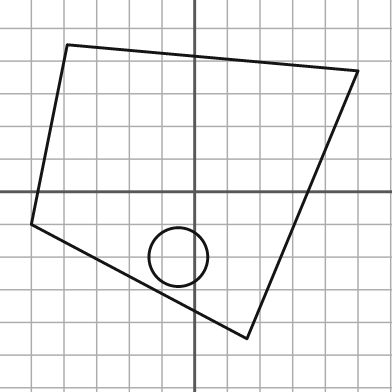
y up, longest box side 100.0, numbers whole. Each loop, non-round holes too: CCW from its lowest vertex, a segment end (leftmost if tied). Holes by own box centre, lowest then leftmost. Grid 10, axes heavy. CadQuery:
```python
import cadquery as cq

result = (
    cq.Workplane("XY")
    .moveTo(16.0, -45.0)
    .lineTo(50.0, 37.0)
    .lineTo(-39.0, 45.0)
    .lineTo(-50.0, -10.0)
    .close()
    .moveTo(-5.0, -20.0)
    .circle(9.0)
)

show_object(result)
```